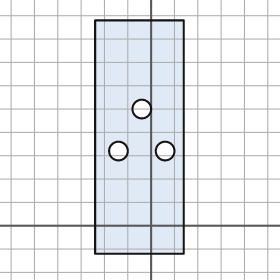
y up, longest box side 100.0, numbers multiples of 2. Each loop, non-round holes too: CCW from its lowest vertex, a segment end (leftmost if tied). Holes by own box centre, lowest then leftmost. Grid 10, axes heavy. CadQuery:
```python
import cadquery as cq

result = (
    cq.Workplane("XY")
    .moveTo(-24.0, -12.0)
    .lineTo(14.0, -12.0)
    .lineTo(14.0, 88.0)
    .lineTo(-24.0, 88.0)
    .close()
    .moveTo(-14.0, 32.0)
    .circle(4.0)
    .moveTo(6.0, 32.0)
    .circle(4.0)
    .moveTo(-4.0, 50.0)
    .circle(4.0)
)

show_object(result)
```